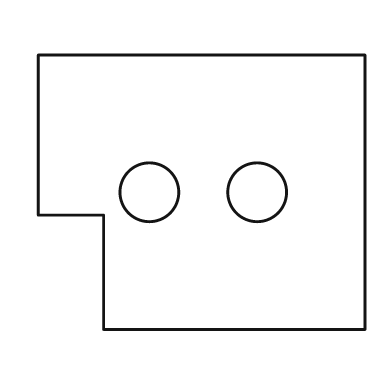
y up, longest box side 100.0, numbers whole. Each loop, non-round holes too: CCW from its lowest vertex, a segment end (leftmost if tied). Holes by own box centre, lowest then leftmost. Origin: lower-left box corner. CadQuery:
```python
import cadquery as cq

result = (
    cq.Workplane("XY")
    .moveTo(20.0, 0.0)
    .lineTo(100.0, 0.0)
    .lineTo(100.0, 84.0)
    .lineTo(0.0, 84.0)
    .lineTo(0.0, 35.0)
    .lineTo(20.0, 35.0)
    .close()
    .moveTo(34.0, 42.0)
    .circle(9.0)
    .moveTo(67.0, 42.0)
    .circle(9.0)
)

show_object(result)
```